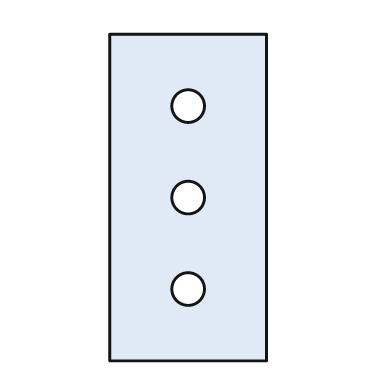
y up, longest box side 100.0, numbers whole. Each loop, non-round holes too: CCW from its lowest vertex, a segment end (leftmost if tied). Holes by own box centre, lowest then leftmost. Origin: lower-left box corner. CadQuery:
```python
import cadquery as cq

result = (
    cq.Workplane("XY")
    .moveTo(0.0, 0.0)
    .lineTo(48.0, 0.0)
    .lineTo(48.0, 100.0)
    .lineTo(0.0, 100.0)
    .close()
    .moveTo(24.0, 22.0)
    .circle(5.0)
    .moveTo(24.0, 50.0)
    .circle(5.0)
    .moveTo(24.0, 78.0)
    .circle(5.0)
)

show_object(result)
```